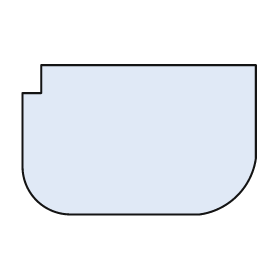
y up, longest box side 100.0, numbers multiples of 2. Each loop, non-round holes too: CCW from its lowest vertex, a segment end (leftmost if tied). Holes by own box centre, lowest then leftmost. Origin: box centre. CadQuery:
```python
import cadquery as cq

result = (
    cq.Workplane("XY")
    .moveTo(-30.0, -32.0)
    .lineTo(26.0, -32.0)
    .threePointArc((42.0, -24.0), (50.0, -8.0))
    .lineTo(50.0, 32.0)
    .lineTo(-42.0, 32.0)
    .lineTo(-42.0, 20.0)
    .lineTo(-50.0, 20.0)
    .lineTo(-50.0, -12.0)
    .threePointArc((-44.0, -26.0), (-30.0, -32.0))
    .close()
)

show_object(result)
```